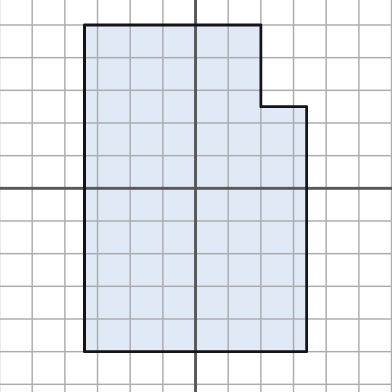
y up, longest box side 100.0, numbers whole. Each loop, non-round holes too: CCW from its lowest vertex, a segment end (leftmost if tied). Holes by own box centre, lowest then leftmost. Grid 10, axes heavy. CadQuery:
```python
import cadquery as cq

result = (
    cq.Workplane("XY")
    .moveTo(-34.0, -50.0)
    .lineTo(34.0, -50.0)
    .lineTo(34.0, 25.0)
    .lineTo(20.0, 25.0)
    .lineTo(20.0, 50.0)
    .lineTo(-34.0, 50.0)
    .close()
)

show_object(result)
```